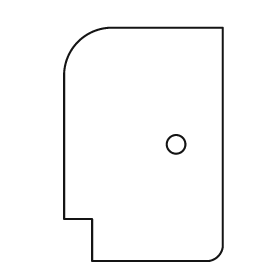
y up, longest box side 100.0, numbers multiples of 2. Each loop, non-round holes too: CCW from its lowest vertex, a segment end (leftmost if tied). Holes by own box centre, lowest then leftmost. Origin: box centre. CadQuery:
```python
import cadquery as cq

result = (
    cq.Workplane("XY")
    .moveTo(-22.0, -50.0)
    .lineTo(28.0, -50.0)
    .threePointArc((32.0, -48.0), (34.0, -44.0))
    .lineTo(34.0, 50.0)
    .lineTo(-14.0, 50.0)
    .threePointArc((-28.0, 44.0), (-34.0, 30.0))
    .lineTo(-34.0, -32.0)
    .lineTo(-22.0, -32.0)
    .close()
    .moveTo(14.0, 0.0)
    .circle(4.0)
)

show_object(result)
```